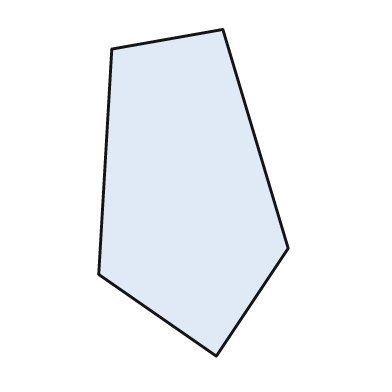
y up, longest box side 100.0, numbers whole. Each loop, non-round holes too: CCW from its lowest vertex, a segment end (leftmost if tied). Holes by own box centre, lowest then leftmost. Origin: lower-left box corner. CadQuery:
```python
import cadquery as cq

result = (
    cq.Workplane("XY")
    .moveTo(36.0, 0.0)
    .lineTo(58.0, 33.0)
    .lineTo(38.0, 100.0)
    .lineTo(4.0, 94.0)
    .lineTo(0.0, 25.0)
    .close()
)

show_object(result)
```